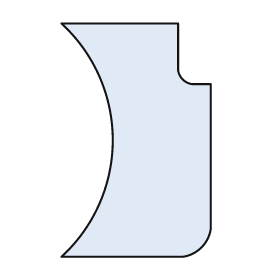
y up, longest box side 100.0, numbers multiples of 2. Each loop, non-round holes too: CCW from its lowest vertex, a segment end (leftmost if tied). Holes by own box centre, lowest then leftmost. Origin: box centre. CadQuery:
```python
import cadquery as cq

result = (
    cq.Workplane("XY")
    .moveTo(-32.0, -50.0)
    .lineTo(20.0, -50.0)
    .threePointArc((28.0, -46.0), (32.0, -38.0))
    .lineTo(32.0, 24.0)
    .lineTo(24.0, 24.0)
    .threePointArc((20.0, 26.0), (18.0, 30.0))
    .lineTo(18.0, 50.0)
    .lineTo(-32.0, 50.0)
    .threePointArc((-10.0, 0.0), (-32.0, -50.0))
    .close()
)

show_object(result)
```